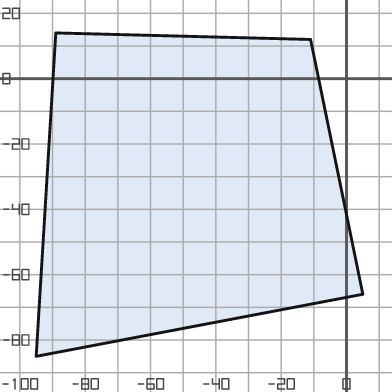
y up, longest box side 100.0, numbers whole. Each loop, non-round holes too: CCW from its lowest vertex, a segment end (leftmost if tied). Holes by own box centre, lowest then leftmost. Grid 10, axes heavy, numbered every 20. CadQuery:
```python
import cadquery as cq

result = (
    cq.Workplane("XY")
    .moveTo(-95.0, -85.0)
    .lineTo(5.0, -66.0)
    .lineTo(-11.0, 12.0)
    .lineTo(-89.0, 14.0)
    .close()
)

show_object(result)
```